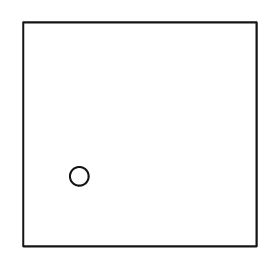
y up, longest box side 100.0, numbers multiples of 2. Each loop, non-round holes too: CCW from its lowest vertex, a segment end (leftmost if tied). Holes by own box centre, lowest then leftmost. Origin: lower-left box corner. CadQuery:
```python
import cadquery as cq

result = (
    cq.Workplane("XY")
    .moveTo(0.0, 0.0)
    .lineTo(100.0, 0.0)
    .lineTo(100.0, 96.0)
    .lineTo(0.0, 96.0)
    .close()
    .moveTo(24.0, 30.0)
    .circle(4.0)
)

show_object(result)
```